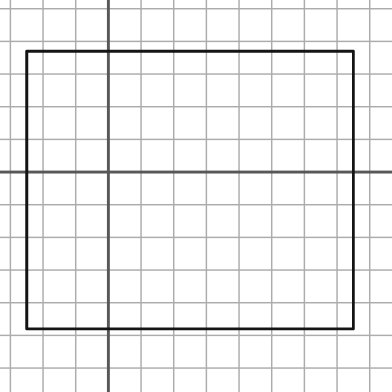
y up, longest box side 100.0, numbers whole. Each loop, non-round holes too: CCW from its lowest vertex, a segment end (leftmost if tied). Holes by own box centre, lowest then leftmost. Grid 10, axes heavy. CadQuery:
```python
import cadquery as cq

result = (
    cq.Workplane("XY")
    .moveTo(-25.0, -48.0)
    .lineTo(75.0, -48.0)
    .lineTo(75.0, 37.0)
    .lineTo(-25.0, 37.0)
    .close()
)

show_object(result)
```